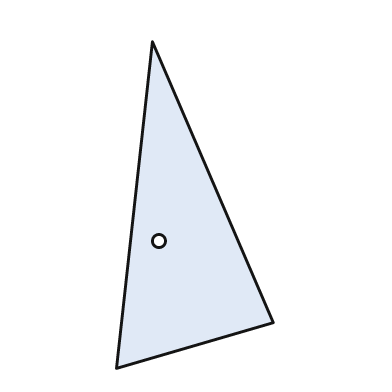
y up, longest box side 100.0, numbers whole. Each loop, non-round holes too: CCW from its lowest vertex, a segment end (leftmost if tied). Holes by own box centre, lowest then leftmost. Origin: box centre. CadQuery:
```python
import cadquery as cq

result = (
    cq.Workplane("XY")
    .moveTo(-24.0, -50.0)
    .lineTo(24.0, -36.0)
    .lineTo(-13.0, 50.0)
    .close()
    .moveTo(-11.0, -11.0)
    .circle(2.0)
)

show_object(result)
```